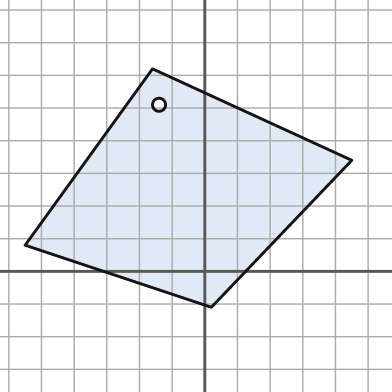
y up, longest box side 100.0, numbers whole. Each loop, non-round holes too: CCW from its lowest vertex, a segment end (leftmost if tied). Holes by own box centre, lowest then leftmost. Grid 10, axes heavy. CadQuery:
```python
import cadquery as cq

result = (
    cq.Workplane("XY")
    .moveTo(2.0, -11.0)
    .lineTo(45.0, 34.0)
    .lineTo(-16.0, 62.0)
    .lineTo(-55.0, 8.0)
    .close()
    .moveTo(-14.0, 51.0)
    .circle(2.0)
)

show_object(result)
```